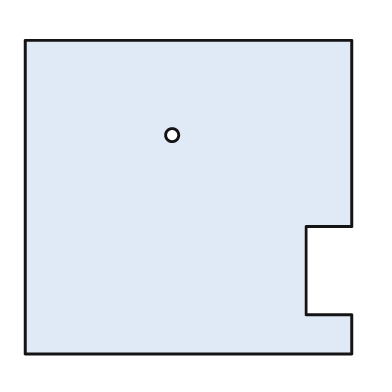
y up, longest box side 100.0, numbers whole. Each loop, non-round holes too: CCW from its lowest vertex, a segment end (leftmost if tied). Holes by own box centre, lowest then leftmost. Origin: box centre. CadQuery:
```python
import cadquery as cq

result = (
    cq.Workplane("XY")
    .moveTo(-50.0, -48.0)
    .lineTo(50.0, -48.0)
    .lineTo(50.0, -36.0)
    .lineTo(36.0, -36.0)
    .lineTo(36.0, -9.0)
    .lineTo(50.0, -9.0)
    .lineTo(50.0, 48.0)
    .lineTo(-50.0, 48.0)
    .close()
    .moveTo(-5.0, 19.0)
    .circle(2.0)
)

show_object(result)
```